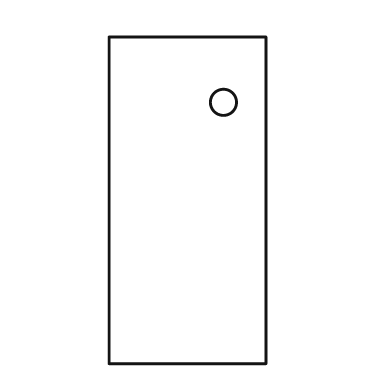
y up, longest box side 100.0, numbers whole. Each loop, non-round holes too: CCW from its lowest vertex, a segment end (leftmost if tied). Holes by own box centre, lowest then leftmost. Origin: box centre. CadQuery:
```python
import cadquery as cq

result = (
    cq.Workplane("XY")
    .moveTo(-24.0, -50.0)
    .lineTo(24.0, -50.0)
    .lineTo(24.0, 50.0)
    .lineTo(-24.0, 50.0)
    .close()
    .moveTo(11.0, 30.0)
    .circle(4.0)
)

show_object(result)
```